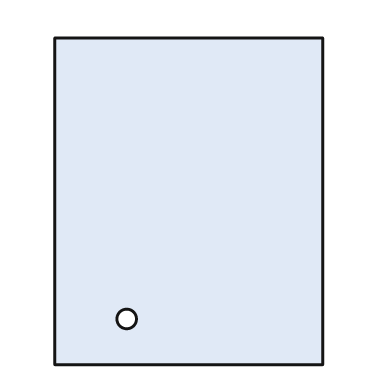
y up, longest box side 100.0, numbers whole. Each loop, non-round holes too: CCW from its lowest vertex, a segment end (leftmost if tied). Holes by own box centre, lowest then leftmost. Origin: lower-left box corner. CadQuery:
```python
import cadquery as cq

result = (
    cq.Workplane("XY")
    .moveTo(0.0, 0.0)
    .lineTo(82.0, 0.0)
    .lineTo(82.0, 100.0)
    .lineTo(0.0, 100.0)
    .close()
    .moveTo(22.0, 14.0)
    .circle(3.0)
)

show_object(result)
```